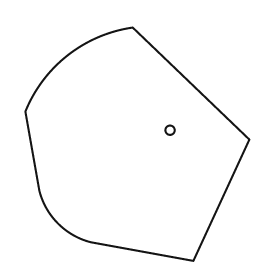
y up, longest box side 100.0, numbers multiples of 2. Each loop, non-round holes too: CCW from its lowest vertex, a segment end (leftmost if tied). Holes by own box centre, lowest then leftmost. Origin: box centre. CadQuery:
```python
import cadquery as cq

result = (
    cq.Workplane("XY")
    .moveTo(24.0, -50.0)
    .lineTo(48.0, 2.0)
    .lineTo(-2.0, 50.0)
    .threePointArc((-30.0, 38.0), (-48.0, 14.0))
    .lineTo(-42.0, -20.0)
    .threePointArc((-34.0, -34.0), (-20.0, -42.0))
    .close()
    .moveTo(14.0, 6.0)
    .circle(2.0)
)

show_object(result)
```